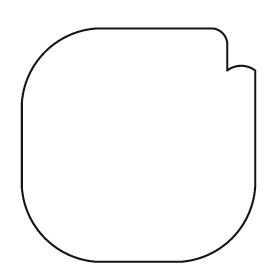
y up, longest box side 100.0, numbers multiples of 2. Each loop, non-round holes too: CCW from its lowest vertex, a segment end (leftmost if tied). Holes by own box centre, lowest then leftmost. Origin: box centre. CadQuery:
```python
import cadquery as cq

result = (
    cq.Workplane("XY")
    .moveTo(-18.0, -50.0)
    .lineTo(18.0, -50.0)
    .threePointArc((40.0, -40.0), (50.0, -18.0))
    .lineTo(50.0, 32.0)
    .threePointArc((44.0, 34.0), (38.0, 32.0))
    .lineTo(38.0, 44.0)
    .threePointArc((36.0, 48.0), (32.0, 50.0))
    .lineTo(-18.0, 50.0)
    .threePointArc((-40.0, 40.0), (-50.0, 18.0))
    .lineTo(-50.0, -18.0)
    .threePointArc((-40.0, -40.0), (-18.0, -50.0))
    .close()
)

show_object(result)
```